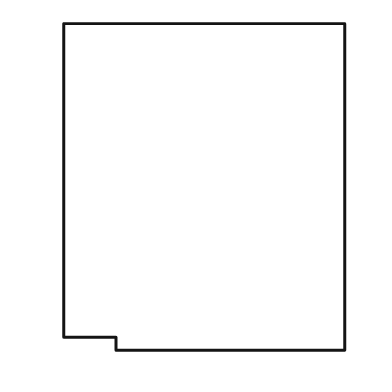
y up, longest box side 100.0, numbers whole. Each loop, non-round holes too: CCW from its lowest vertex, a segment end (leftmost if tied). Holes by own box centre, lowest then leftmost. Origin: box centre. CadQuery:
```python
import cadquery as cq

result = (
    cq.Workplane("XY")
    .moveTo(-27.0, -50.0)
    .lineTo(43.0, -50.0)
    .lineTo(43.0, 50.0)
    .lineTo(-43.0, 50.0)
    .lineTo(-43.0, -46.0)
    .lineTo(-27.0, -46.0)
    .close()
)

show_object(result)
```